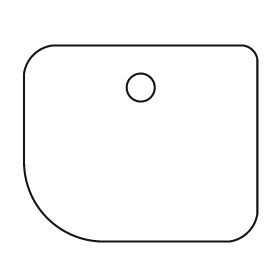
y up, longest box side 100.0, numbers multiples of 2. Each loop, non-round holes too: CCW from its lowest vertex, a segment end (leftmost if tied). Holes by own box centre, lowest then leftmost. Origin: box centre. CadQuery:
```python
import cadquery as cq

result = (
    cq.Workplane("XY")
    .moveTo(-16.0, -42.0)
    .lineTo(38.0, -42.0)
    .threePointArc((46.0, -38.0), (50.0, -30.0))
    .lineTo(50.0, 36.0)
    .threePointArc((48.0, 40.0), (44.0, 42.0))
    .lineTo(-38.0, 42.0)
    .threePointArc((-46.0, 38.0), (-50.0, 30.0))
    .lineTo(-50.0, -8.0)
    .threePointArc((-40.0, -32.0), (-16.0, -42.0))
    .close()
    .moveTo(0.0, 24.0)
    .circle(6.0)
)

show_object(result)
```